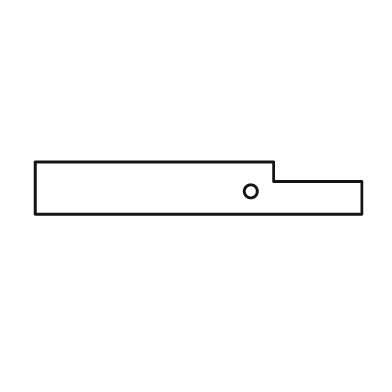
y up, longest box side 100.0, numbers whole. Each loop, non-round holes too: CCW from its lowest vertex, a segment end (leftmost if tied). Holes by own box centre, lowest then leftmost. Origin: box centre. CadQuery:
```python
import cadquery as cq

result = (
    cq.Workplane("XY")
    .moveTo(-50.0, -8.0)
    .lineTo(50.0, -8.0)
    .lineTo(50.0, 2.0)
    .lineTo(23.0, 2.0)
    .lineTo(23.0, 8.0)
    .lineTo(-50.0, 8.0)
    .close()
    .moveTo(16.0, -1.0)
    .circle(2.0)
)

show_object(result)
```